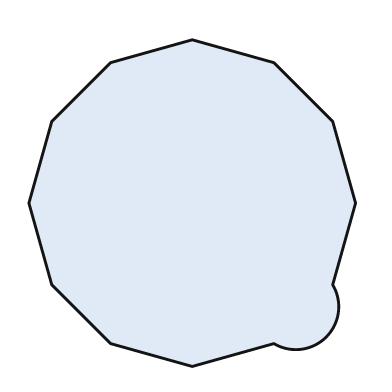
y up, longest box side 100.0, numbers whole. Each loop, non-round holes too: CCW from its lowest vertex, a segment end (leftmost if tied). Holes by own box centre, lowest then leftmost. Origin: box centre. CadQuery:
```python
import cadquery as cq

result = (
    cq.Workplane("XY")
    .moveTo(0.0, -50.0)
    .lineTo(25.0, -43.0)
    .threePointArc((41.0, -41.0), (43.0, -25.0))
    .lineTo(50.0, 0.0)
    .lineTo(43.0, 25.0)
    .lineTo(25.0, 43.0)
    .lineTo(0.0, 50.0)
    .lineTo(-25.0, 43.0)
    .lineTo(-43.0, 25.0)
    .lineTo(-50.0, 0.0)
    .lineTo(-43.0, -25.0)
    .lineTo(-25.0, -43.0)
    .close()
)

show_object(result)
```